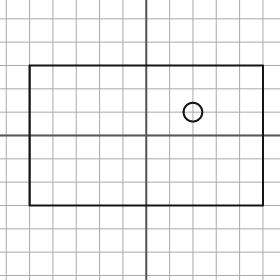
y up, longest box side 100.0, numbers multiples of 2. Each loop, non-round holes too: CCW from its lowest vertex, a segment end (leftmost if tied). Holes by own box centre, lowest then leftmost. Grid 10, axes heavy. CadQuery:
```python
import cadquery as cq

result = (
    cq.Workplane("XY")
    .moveTo(-50.0, -30.0)
    .lineTo(50.0, -30.0)
    .lineTo(50.0, 30.0)
    .lineTo(-50.0, 30.0)
    .close()
    .moveTo(20.0, 10.0)
    .circle(4.0)
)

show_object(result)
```